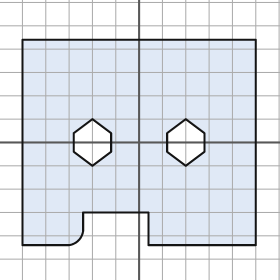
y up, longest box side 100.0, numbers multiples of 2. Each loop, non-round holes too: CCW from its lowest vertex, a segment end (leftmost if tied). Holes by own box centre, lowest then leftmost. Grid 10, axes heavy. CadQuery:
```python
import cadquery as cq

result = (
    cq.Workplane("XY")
    .moveTo(-50.0, -44.0)
    .lineTo(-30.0, -44.0)
    .threePointArc((-26.0, -42.0), (-24.0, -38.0))
    .lineTo(-24.0, -30.0)
    .lineTo(4.0, -30.0)
    .lineTo(4.0, -44.0)
    .lineTo(50.0, -44.0)
    .lineTo(50.0, 44.0)
    .lineTo(-50.0, 44.0)
    .close()
    .moveTo(-20.0, -10.0)
    .lineTo(-12.0, -4.0)
    .lineTo(-12.0, 4.0)
    .lineTo(-20.0, 10.0)
    .lineTo(-28.0, 4.0)
    .lineTo(-28.0, -4.0)
    .close()
    .moveTo(20.0, -10.0)
    .lineTo(28.0, -4.0)
    .lineTo(28.0, 4.0)
    .lineTo(20.0, 10.0)
    .lineTo(12.0, 4.0)
    .lineTo(12.0, -4.0)
    .close()
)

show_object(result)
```